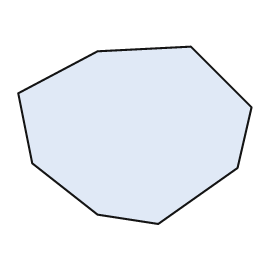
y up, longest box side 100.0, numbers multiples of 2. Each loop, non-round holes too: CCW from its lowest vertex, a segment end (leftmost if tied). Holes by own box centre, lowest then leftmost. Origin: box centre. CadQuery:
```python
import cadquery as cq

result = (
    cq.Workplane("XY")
    .moveTo(10.0, -38.0)
    .lineTo(44.0, -14.0)
    .lineTo(50.0, 12.0)
    .lineTo(24.0, 38.0)
    .lineTo(-16.0, 36.0)
    .lineTo(-50.0, 18.0)
    .lineTo(-44.0, -12.0)
    .lineTo(-16.0, -34.0)
    .close()
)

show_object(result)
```